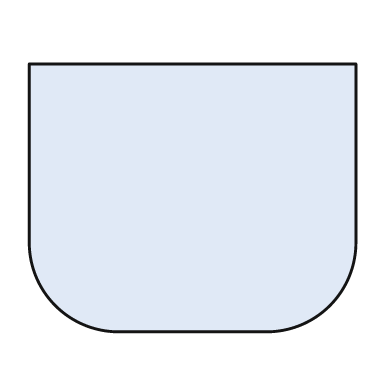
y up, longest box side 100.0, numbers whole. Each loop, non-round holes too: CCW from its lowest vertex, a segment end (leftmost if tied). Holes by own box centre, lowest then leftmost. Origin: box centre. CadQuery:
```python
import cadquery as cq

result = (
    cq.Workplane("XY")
    .moveTo(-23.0, -41.0)
    .lineTo(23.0, -41.0)
    .threePointArc((42.0, -33.0), (50.0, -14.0))
    .lineTo(50.0, 41.0)
    .lineTo(-50.0, 41.0)
    .lineTo(-50.0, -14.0)
    .threePointArc((-42.0, -33.0), (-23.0, -41.0))
    .close()
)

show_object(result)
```